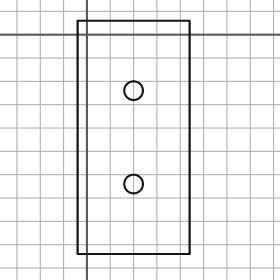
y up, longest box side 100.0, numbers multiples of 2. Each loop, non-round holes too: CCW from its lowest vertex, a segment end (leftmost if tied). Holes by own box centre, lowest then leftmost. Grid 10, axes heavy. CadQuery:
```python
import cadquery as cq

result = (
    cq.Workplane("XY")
    .moveTo(-4.0, -94.0)
    .lineTo(44.0, -94.0)
    .lineTo(44.0, 6.0)
    .lineTo(-4.0, 6.0)
    .close()
    .moveTo(20.0, -64.0)
    .circle(4.0)
    .moveTo(20.0, -24.0)
    .circle(4.0)
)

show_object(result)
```